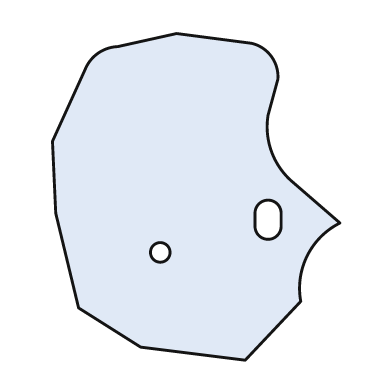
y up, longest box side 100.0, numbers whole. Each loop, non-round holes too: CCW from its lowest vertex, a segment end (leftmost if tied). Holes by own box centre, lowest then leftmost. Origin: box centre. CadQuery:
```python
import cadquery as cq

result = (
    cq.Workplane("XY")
    .moveTo(15.0, -50.0)
    .lineTo(32.0, -32.0)
    .threePointArc((34.0, -18.0), (44.0, -8.0))
    .lineTo(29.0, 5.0)
    .threePointArc((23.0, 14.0), (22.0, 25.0))
    .lineTo(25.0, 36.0)
    .threePointArc((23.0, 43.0), (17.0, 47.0))
    .lineTo(-6.0, 50.0)
    .lineTo(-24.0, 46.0)
    .threePointArc((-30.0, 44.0), (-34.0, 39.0))
    .lineTo(-44.0, 17.0)
    .lineTo(-43.0, -5.0)
    .lineTo(-36.0, -34.0)
    .lineTo(-17.0, -46.0)
    .close()
    .moveTo(-11.0, -17.0)
    .circle(3.0)
    .moveTo(18.0, -9.0)
    .threePointArc((22.0, -13.0), (26.0, -9.0))
    .lineTo(26.0, -5.0)
    .threePointArc((22.0, -1.0), (18.0, -5.0))
    .close()
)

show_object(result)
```